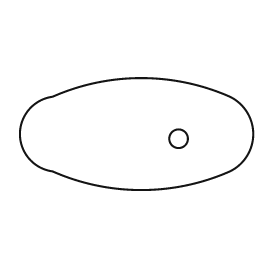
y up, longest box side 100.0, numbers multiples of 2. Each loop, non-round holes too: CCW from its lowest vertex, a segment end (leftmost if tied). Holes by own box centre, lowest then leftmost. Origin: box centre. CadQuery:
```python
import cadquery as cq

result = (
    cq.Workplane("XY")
    .moveTo(-36.0, -16.0)
    .threePointArc((2.0, -24.0), (40.0, -16.0))
    .threePointArc((50.0, 0.0), (40.0, 16.0))
    .threePointArc((2.0, 24.0), (-36.0, 16.0))
    .threePointArc((-50.0, 0.0), (-36.0, -16.0))
    .close()
    .moveTo(18.0, -2.0)
    .circle(4.0)
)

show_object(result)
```